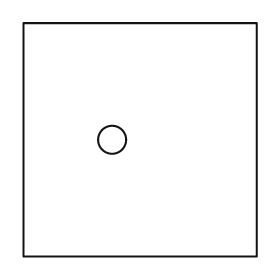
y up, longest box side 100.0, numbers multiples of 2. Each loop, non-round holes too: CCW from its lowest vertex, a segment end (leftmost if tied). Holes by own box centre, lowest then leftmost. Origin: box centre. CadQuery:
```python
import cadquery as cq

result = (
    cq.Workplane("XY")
    .moveTo(-50.0, -50.0)
    .lineTo(50.0, -50.0)
    .lineTo(50.0, 50.0)
    .lineTo(-50.0, 50.0)
    .close()
    .moveTo(-12.0, 0.0)
    .circle(6.0)
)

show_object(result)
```